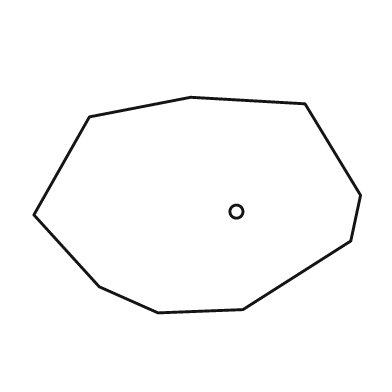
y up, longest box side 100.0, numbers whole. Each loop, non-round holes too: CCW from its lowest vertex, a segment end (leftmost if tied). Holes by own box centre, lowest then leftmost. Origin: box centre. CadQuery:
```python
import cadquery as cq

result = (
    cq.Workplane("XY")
    .moveTo(-12.0, -33.0)
    .lineTo(14.0, -32.0)
    .lineTo(47.0, -11.0)
    .lineTo(50.0, 3.0)
    .lineTo(33.0, 31.0)
    .lineTo(-2.0, 33.0)
    .lineTo(-33.0, 27.0)
    .lineTo(-50.0, -3.0)
    .lineTo(-30.0, -25.0)
    .close()
    .moveTo(12.0, -2.0)
    .circle(2.0)
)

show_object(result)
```